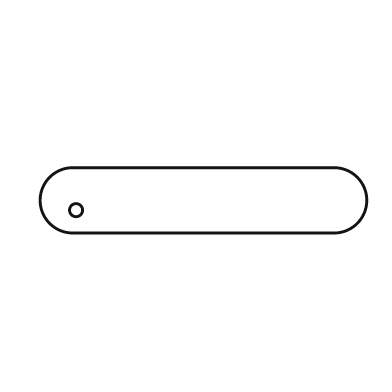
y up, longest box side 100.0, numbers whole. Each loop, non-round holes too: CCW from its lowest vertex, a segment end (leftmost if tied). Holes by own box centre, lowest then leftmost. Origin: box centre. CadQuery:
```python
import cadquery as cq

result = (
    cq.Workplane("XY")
    .moveTo(-40.0, -10.0)
    .lineTo(40.0, -10.0)
    .threePointArc((50.0, 0.0), (40.0, 10.0))
    .lineTo(-40.0, 10.0)
    .threePointArc((-50.0, 0.0), (-40.0, -10.0))
    .close()
    .moveTo(-39.0, -3.0)
    .circle(2.0)
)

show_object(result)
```